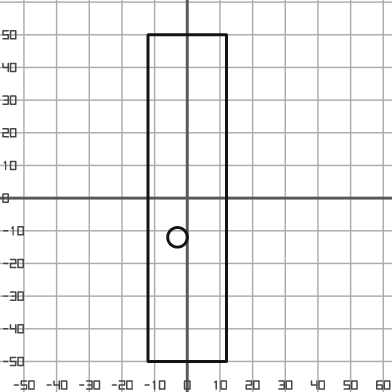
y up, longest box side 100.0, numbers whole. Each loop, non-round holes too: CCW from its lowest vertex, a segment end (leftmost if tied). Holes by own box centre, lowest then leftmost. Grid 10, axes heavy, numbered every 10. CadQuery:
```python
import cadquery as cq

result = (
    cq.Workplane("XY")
    .moveTo(-12.0, -50.0)
    .lineTo(12.0, -50.0)
    .lineTo(12.0, 50.0)
    .lineTo(-12.0, 50.0)
    .close()
    .moveTo(-3.0, -12.0)
    .circle(3.0)
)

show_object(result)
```